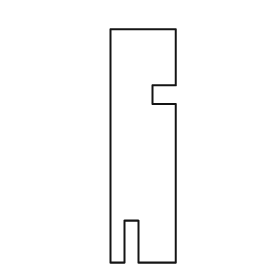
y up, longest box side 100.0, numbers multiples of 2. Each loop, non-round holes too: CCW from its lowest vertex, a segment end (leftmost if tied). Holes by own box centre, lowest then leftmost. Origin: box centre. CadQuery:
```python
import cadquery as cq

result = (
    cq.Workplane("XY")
    .moveTo(-14.0, -50.0)
    .lineTo(-8.0, -50.0)
    .lineTo(-8.0, -32.0)
    .lineTo(-2.0, -32.0)
    .lineTo(-2.0, -50.0)
    .lineTo(14.0, -50.0)
    .lineTo(14.0, 18.0)
    .lineTo(4.0, 18.0)
    .lineTo(4.0, 26.0)
    .lineTo(14.0, 26.0)
    .lineTo(14.0, 50.0)
    .lineTo(-14.0, 50.0)
    .close()
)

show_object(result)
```